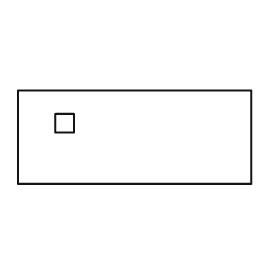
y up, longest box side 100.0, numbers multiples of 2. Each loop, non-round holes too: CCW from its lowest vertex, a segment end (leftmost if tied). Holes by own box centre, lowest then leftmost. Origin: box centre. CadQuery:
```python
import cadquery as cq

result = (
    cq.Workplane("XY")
    .moveTo(-50.0, -20.0)
    .lineTo(50.0, -20.0)
    .lineTo(50.0, 20.0)
    .lineTo(-50.0, 20.0)
    .close()
    .moveTo(-34.0, 2.0)
    .lineTo(-26.0, 2.0)
    .lineTo(-26.0, 10.0)
    .lineTo(-34.0, 10.0)
    .close()
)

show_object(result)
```